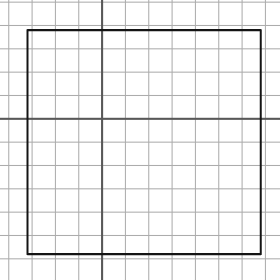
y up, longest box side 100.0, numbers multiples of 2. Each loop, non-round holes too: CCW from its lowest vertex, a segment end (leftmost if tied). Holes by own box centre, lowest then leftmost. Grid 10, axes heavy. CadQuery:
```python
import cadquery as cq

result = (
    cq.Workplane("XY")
    .moveTo(-32.0, -58.0)
    .lineTo(68.0, -58.0)
    .lineTo(68.0, 38.0)
    .lineTo(-32.0, 38.0)
    .close()
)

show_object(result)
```